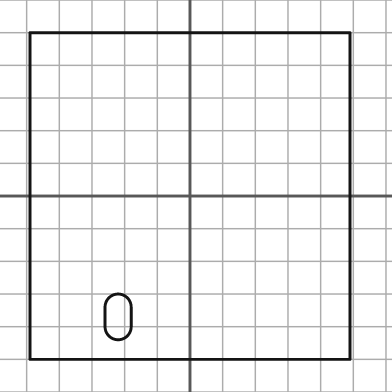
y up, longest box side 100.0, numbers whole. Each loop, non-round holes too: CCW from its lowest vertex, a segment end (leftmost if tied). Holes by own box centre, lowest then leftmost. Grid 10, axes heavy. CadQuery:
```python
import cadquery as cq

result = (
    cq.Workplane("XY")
    .moveTo(-49.0, -50.0)
    .lineTo(49.0, -50.0)
    .lineTo(49.0, 50.0)
    .lineTo(-49.0, 50.0)
    .close()
    .moveTo(-26.0, -40.0)
    .threePointArc((-22.0, -44.0), (-18.0, -40.0))
    .lineTo(-18.0, -34.0)
    .threePointArc((-22.0, -30.0), (-26.0, -34.0))
    .close()
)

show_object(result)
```